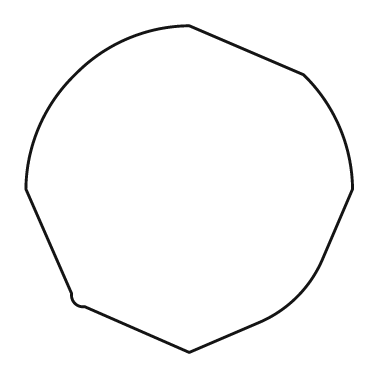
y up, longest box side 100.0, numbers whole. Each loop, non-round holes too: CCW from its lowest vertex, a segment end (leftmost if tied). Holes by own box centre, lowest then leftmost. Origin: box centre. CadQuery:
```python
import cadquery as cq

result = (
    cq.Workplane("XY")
    .moveTo(0.0, -50.0)
    .lineTo(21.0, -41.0)
    .threePointArc((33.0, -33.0), (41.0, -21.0))
    .lineTo(50.0, 0.0)
    .threePointArc((46.0, 19.0), (35.0, 35.0))
    .lineTo(0.0, 50.0)
    .threePointArc((-19.0, 46.0), (-35.0, 35.0))
    .threePointArc((-46.0, 19.0), (-50.0, 0.0))
    .lineTo(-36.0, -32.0)
    .threePointArc((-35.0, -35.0), (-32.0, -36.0))
    .close()
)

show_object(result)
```